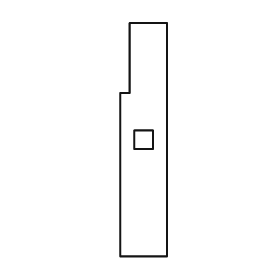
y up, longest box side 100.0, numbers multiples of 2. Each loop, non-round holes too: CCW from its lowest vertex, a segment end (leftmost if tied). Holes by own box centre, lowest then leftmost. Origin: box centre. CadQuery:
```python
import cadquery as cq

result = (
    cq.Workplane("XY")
    .moveTo(-10.0, -50.0)
    .lineTo(10.0, -50.0)
    .lineTo(10.0, 50.0)
    .lineTo(-6.0, 50.0)
    .lineTo(-6.0, 20.0)
    .lineTo(-10.0, 20.0)
    .close()
    .moveTo(-4.0, -4.0)
    .lineTo(4.0, -4.0)
    .lineTo(4.0, 4.0)
    .lineTo(-4.0, 4.0)
    .close()
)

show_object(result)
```